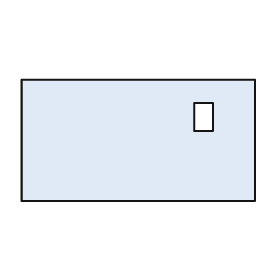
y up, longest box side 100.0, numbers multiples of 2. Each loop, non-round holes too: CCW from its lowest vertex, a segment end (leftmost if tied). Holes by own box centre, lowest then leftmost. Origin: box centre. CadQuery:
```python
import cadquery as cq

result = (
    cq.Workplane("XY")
    .moveTo(-50.0, -26.0)
    .lineTo(50.0, -26.0)
    .lineTo(50.0, 26.0)
    .lineTo(-50.0, 26.0)
    .close()
    .moveTo(24.0, 4.0)
    .lineTo(32.0, 4.0)
    .lineTo(32.0, 16.0)
    .lineTo(24.0, 16.0)
    .close()
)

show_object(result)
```